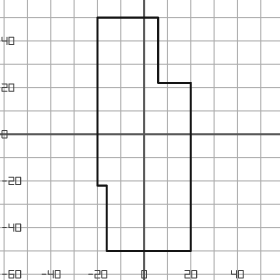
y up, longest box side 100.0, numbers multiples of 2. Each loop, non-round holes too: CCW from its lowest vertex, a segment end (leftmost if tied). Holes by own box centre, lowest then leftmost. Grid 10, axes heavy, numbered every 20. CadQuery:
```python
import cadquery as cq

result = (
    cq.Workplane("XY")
    .moveTo(-16.0, -50.0)
    .lineTo(20.0, -50.0)
    .lineTo(20.0, 22.0)
    .lineTo(6.0, 22.0)
    .lineTo(6.0, 50.0)
    .lineTo(-20.0, 50.0)
    .lineTo(-20.0, -22.0)
    .lineTo(-16.0, -22.0)
    .close()
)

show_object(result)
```